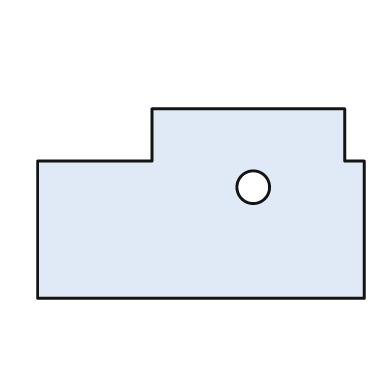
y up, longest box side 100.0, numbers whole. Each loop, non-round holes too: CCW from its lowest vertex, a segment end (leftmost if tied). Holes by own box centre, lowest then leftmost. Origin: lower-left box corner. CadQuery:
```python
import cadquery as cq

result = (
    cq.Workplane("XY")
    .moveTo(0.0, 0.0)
    .lineTo(100.0, 0.0)
    .lineTo(100.0, 42.0)
    .lineTo(94.0, 42.0)
    .lineTo(94.0, 58.0)
    .lineTo(35.0, 58.0)
    .lineTo(35.0, 42.0)
    .lineTo(0.0, 42.0)
    .close()
    .moveTo(66.0, 34.0)
    .circle(5.0)
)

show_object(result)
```